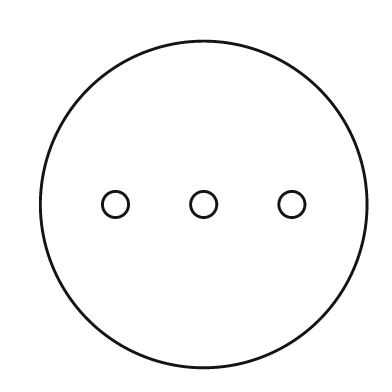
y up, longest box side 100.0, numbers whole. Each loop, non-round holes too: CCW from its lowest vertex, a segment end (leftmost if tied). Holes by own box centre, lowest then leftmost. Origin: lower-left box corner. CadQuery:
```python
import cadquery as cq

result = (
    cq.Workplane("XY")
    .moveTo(50.0, 50.0)
    .circle(50.0)
    .moveTo(23.0, 50.0)
    .circle(4.0)
    .moveTo(50.0, 50.0)
    .circle(4.0)
    .moveTo(77.0, 50.0)
    .circle(4.0)
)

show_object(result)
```